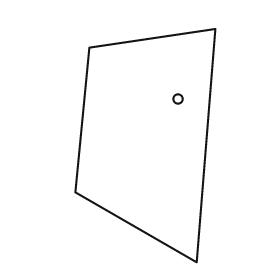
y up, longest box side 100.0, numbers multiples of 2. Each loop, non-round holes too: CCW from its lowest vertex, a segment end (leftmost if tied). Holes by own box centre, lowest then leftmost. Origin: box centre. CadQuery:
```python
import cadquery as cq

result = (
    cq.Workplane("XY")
    .moveTo(22.0, -50.0)
    .lineTo(30.0, 50.0)
    .lineTo(-24.0, 42.0)
    .lineTo(-30.0, -20.0)
    .close()
    .moveTo(14.0, 20.0)
    .circle(2.0)
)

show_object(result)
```